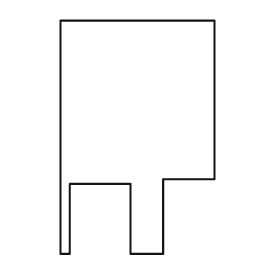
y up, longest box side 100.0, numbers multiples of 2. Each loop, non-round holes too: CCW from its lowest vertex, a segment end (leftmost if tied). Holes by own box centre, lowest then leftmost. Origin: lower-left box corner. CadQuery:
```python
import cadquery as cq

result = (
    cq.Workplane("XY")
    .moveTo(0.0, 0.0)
    .lineTo(4.0, 0.0)
    .lineTo(4.0, 30.0)
    .lineTo(30.0, 30.0)
    .lineTo(30.0, 0.0)
    .lineTo(44.0, 0.0)
    .lineTo(44.0, 32.0)
    .lineTo(66.0, 32.0)
    .lineTo(66.0, 100.0)
    .lineTo(0.0, 100.0)
    .close()
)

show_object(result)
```